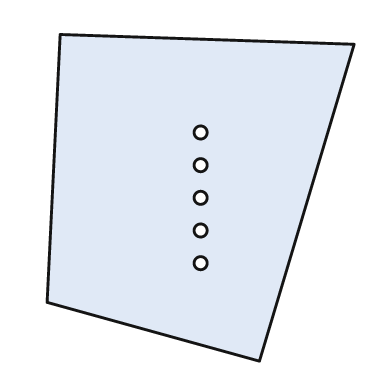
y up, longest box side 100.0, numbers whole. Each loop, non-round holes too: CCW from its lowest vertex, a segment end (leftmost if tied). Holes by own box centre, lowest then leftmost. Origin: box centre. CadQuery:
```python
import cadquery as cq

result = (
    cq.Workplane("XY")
    .moveTo(18.0, -50.0)
    .lineTo(47.0, 47.0)
    .lineTo(-43.0, 50.0)
    .lineTo(-47.0, -32.0)
    .close()
    .moveTo(0.0, -20.0)
    .circle(2.0)
    .moveTo(0.0, -10.0)
    .circle(2.0)
    .moveTo(0.0, 0.0)
    .circle(2.0)
    .moveTo(0.0, 10.0)
    .circle(2.0)
    .moveTo(0.0, 20.0)
    .circle(2.0)
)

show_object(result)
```